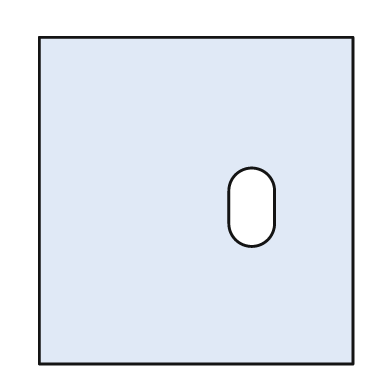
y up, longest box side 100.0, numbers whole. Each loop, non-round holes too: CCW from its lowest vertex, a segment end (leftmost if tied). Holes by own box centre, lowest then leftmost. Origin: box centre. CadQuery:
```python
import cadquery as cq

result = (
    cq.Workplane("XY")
    .moveTo(-48.0, -50.0)
    .lineTo(48.0, -50.0)
    .lineTo(48.0, 50.0)
    .lineTo(-48.0, 50.0)
    .close()
    .moveTo(10.0, -7.0)
    .threePointArc((17.0, -14.0), (24.0, -7.0))
    .lineTo(24.0, 3.0)
    .threePointArc((17.0, 10.0), (10.0, 3.0))
    .close()
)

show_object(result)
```